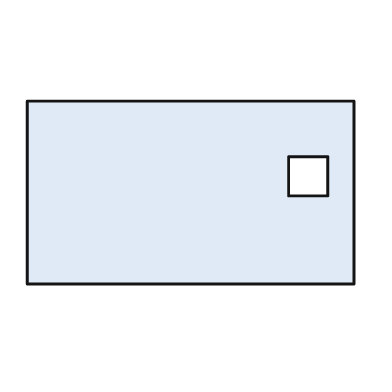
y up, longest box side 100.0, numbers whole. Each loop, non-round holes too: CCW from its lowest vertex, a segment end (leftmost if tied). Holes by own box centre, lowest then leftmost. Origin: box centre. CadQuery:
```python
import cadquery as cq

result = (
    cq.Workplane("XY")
    .moveTo(-50.0, -28.0)
    .lineTo(50.0, -28.0)
    .lineTo(50.0, 28.0)
    .lineTo(-50.0, 28.0)
    .close()
    .moveTo(30.0, -1.0)
    .lineTo(42.0, -1.0)
    .lineTo(42.0, 11.0)
    .lineTo(30.0, 11.0)
    .close()
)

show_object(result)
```